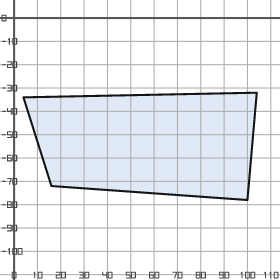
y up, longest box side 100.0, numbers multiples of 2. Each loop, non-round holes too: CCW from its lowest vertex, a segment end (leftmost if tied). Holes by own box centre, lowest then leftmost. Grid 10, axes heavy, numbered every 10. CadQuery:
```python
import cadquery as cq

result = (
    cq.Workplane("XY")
    .moveTo(100.0, -78.0)
    .lineTo(104.0, -32.0)
    .lineTo(4.0, -34.0)
    .lineTo(16.0, -72.0)
    .close()
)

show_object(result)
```